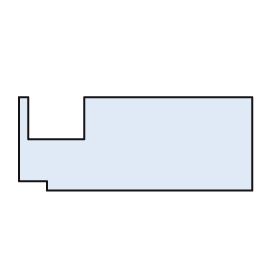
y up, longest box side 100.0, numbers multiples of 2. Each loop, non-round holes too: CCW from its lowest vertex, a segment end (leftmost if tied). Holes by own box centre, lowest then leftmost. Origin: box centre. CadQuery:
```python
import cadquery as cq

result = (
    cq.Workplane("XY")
    .moveTo(-38.0, -20.0)
    .lineTo(50.0, -20.0)
    .lineTo(50.0, 20.0)
    .lineTo(-22.0, 20.0)
    .lineTo(-22.0, 2.0)
    .lineTo(-46.0, 2.0)
    .lineTo(-46.0, 20.0)
    .lineTo(-50.0, 20.0)
    .lineTo(-50.0, -16.0)
    .lineTo(-38.0, -16.0)
    .close()
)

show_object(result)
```